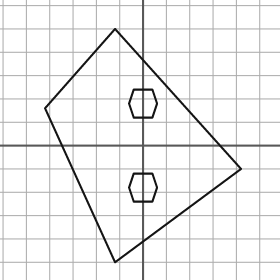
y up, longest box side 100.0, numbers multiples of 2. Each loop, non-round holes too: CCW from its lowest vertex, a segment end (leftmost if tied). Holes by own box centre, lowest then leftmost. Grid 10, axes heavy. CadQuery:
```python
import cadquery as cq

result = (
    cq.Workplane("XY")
    .moveTo(-12.0, -50.0)
    .lineTo(42.0, -10.0)
    .lineTo(-12.0, 50.0)
    .lineTo(-42.0, 16.0)
    .close()
    .moveTo(-4.0, -24.0)
    .lineTo(4.0, -24.0)
    .lineTo(6.0, -18.0)
    .lineTo(4.0, -12.0)
    .lineTo(-4.0, -12.0)
    .lineTo(-6.0, -18.0)
    .close()
    .moveTo(-4.0, 12.0)
    .lineTo(4.0, 12.0)
    .lineTo(6.0, 18.0)
    .lineTo(4.0, 24.0)
    .lineTo(-4.0, 24.0)
    .lineTo(-6.0, 18.0)
    .close()
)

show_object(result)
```